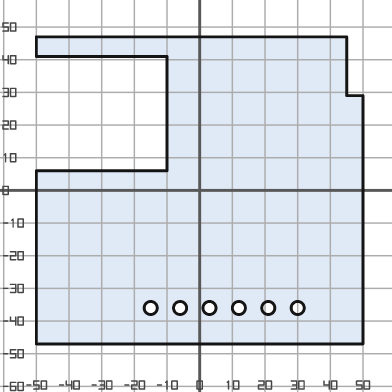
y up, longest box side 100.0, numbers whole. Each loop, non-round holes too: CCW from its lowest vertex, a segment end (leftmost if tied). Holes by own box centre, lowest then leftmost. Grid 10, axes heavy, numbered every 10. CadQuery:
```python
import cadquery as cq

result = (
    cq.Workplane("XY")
    .moveTo(-50.0, -47.0)
    .lineTo(50.0, -47.0)
    .lineTo(50.0, 29.0)
    .lineTo(45.0, 29.0)
    .lineTo(45.0, 47.0)
    .lineTo(-50.0, 47.0)
    .lineTo(-50.0, 41.0)
    .lineTo(-10.0, 41.0)
    .lineTo(-10.0, 6.0)
    .lineTo(-50.0, 6.0)
    .close()
    .moveTo(-15.0, -36.0)
    .circle(2.0)
    .moveTo(-6.0, -36.0)
    .circle(2.0)
    .moveTo(3.0, -36.0)
    .circle(2.0)
    .moveTo(12.0, -36.0)
    .circle(2.0)
    .moveTo(21.0, -36.0)
    .circle(2.0)
    .moveTo(30.0, -36.0)
    .circle(2.0)
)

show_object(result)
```